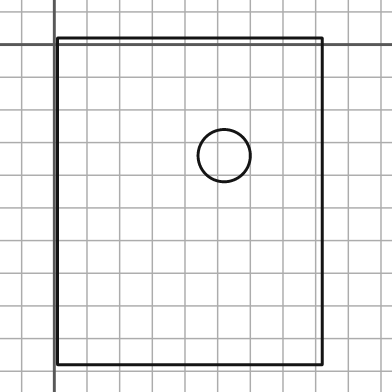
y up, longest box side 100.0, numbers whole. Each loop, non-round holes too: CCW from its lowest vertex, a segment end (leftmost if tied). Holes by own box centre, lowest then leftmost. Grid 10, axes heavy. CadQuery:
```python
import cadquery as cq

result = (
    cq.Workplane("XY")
    .moveTo(1.0, -98.0)
    .lineTo(82.0, -98.0)
    .lineTo(82.0, 2.0)
    .lineTo(1.0, 2.0)
    .close()
    .moveTo(52.0, -34.0)
    .circle(8.0)
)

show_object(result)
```